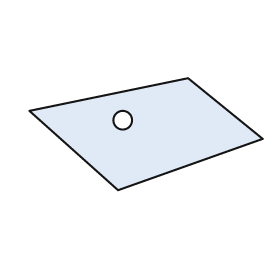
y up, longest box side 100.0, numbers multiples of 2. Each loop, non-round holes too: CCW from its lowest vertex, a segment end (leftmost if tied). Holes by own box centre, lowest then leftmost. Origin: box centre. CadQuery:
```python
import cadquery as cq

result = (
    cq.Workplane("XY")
    .moveTo(-12.0, -24.0)
    .lineTo(50.0, -2.0)
    .lineTo(18.0, 24.0)
    .lineTo(-50.0, 10.0)
    .close()
    .moveTo(-10.0, 6.0)
    .circle(4.0)
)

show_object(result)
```